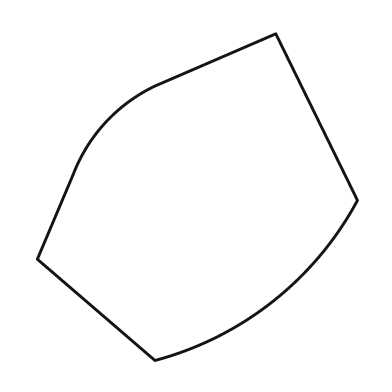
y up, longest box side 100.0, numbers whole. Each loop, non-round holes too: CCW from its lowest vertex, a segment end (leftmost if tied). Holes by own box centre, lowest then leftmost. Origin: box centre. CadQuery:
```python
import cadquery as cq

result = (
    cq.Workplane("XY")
    .moveTo(-13.0, -50.0)
    .threePointArc((23.0, -32.0), (49.0, -1.0))
    .lineTo(24.0, 50.0)
    .lineTo(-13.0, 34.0)
    .threePointArc((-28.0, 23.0), (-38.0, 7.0))
    .lineTo(-49.0, -19.0)
    .close()
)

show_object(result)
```